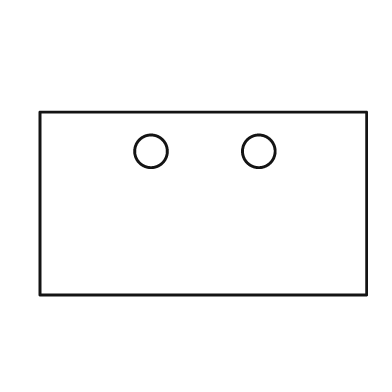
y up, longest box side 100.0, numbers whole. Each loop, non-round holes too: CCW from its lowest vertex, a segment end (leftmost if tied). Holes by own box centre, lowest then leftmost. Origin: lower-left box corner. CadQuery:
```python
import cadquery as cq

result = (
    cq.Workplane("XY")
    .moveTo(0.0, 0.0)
    .lineTo(100.0, 0.0)
    .lineTo(100.0, 56.0)
    .lineTo(0.0, 56.0)
    .close()
    .moveTo(34.0, 44.0)
    .circle(5.0)
    .moveTo(67.0, 44.0)
    .circle(5.0)
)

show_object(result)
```